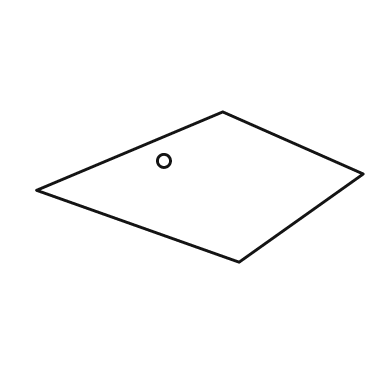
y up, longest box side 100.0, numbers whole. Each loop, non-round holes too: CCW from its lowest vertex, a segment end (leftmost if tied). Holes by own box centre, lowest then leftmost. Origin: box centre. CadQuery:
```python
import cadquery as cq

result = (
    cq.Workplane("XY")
    .moveTo(12.0, -23.0)
    .lineTo(50.0, 4.0)
    .lineTo(7.0, 23.0)
    .lineTo(-50.0, -1.0)
    .close()
    .moveTo(-11.0, 8.0)
    .circle(2.0)
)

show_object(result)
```